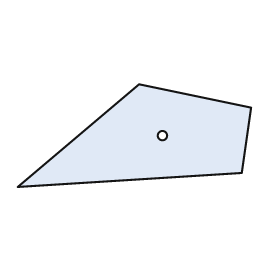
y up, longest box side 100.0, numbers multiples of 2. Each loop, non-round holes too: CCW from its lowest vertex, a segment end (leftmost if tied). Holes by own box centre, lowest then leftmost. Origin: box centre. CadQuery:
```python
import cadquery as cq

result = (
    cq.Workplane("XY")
    .moveTo(-50.0, -22.0)
    .lineTo(46.0, -16.0)
    .lineTo(50.0, 12.0)
    .lineTo(2.0, 22.0)
    .close()
    .moveTo(12.0, 0.0)
    .circle(2.0)
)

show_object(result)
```